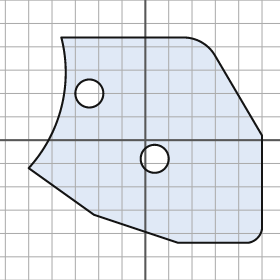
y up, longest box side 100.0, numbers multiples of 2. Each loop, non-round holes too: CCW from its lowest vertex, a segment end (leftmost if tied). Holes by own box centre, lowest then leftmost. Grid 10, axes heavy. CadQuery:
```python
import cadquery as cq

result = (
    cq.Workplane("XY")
    .moveTo(14.0, -44.0)
    .lineTo(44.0, -44.0)
    .threePointArc((48.0, -42.0), (50.0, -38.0))
    .lineTo(50.0, 2.0)
    .lineTo(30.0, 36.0)
    .threePointArc((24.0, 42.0), (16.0, 44.0))
    .lineTo(-36.0, 44.0)
    .threePointArc((-36.0, 14.0), (-50.0, -12.0))
    .lineTo(-22.0, -32.0)
    .close()
    .moveTo(4.0, -8.0)
    .circle(6.0)
    .moveTo(-24.0, 20.0)
    .circle(6.0)
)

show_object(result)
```